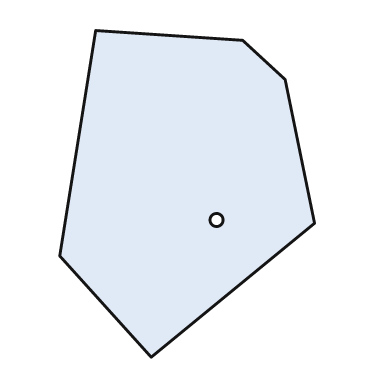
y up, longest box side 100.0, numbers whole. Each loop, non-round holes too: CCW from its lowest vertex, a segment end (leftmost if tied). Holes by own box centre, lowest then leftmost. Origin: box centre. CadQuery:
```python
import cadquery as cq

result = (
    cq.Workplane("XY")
    .moveTo(-11.0, -50.0)
    .lineTo(39.0, -9.0)
    .lineTo(30.0, 35.0)
    .lineTo(17.0, 47.0)
    .lineTo(-28.0, 50.0)
    .lineTo(-39.0, -19.0)
    .close()
    .moveTo(9.0, -8.0)
    .circle(2.0)
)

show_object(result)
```